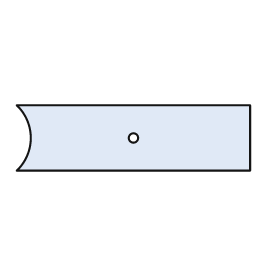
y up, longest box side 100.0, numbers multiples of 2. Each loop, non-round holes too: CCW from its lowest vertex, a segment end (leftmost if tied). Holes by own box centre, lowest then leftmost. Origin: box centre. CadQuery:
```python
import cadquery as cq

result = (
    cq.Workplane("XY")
    .moveTo(-50.0, -14.0)
    .lineTo(50.0, -14.0)
    .lineTo(50.0, 14.0)
    .lineTo(-50.0, 14.0)
    .threePointArc((-44.0, 0.0), (-50.0, -14.0))
    .close()
    .moveTo(0.0, 0.0)
    .circle(2.0)
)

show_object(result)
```